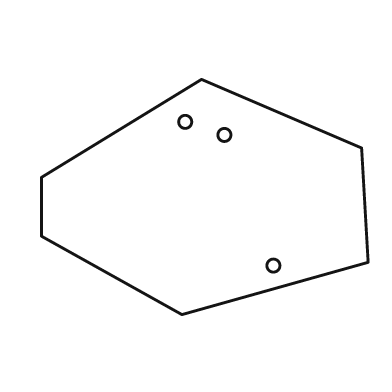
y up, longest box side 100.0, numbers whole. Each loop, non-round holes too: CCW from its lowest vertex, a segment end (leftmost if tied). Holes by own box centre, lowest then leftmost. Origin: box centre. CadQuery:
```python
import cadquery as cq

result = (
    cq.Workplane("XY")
    .moveTo(-7.0, -36.0)
    .lineTo(50.0, -20.0)
    .lineTo(48.0, 15.0)
    .lineTo(-1.0, 36.0)
    .lineTo(-50.0, 6.0)
    .lineTo(-50.0, -12.0)
    .close()
    .moveTo(21.0, -21.0)
    .circle(2.0)
    .moveTo(6.0, 19.0)
    .circle(2.0)
    .moveTo(-6.0, 23.0)
    .circle(2.0)
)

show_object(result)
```